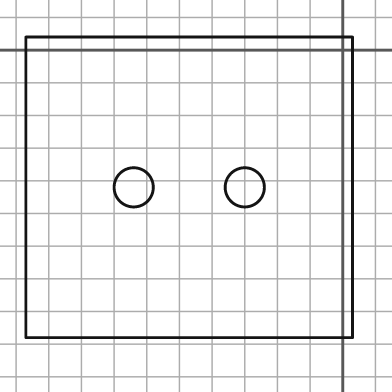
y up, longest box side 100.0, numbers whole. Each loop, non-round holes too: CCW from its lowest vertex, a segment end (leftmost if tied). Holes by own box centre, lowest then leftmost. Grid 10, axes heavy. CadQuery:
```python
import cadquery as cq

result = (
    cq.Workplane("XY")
    .moveTo(-97.0, -88.0)
    .lineTo(3.0, -88.0)
    .lineTo(3.0, 4.0)
    .lineTo(-97.0, 4.0)
    .close()
    .moveTo(-64.0, -42.0)
    .circle(6.0)
    .moveTo(-30.0, -42.0)
    .circle(6.0)
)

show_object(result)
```